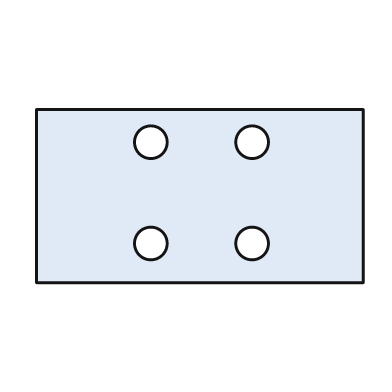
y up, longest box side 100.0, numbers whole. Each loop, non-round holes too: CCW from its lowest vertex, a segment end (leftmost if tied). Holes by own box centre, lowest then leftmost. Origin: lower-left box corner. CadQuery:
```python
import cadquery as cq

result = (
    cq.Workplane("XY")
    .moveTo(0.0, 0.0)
    .lineTo(100.0, 0.0)
    .lineTo(100.0, 53.0)
    .lineTo(0.0, 53.0)
    .close()
    .moveTo(35.0, 12.0)
    .circle(5.0)
    .moveTo(66.0, 12.0)
    .circle(5.0)
    .moveTo(35.0, 43.0)
    .circle(5.0)
    .moveTo(66.0, 43.0)
    .circle(5.0)
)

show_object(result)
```